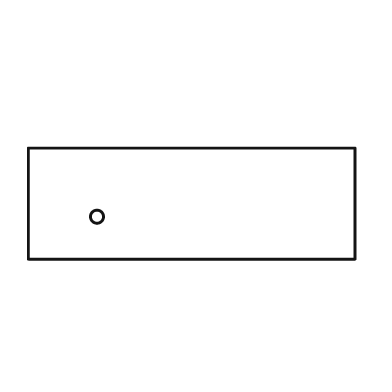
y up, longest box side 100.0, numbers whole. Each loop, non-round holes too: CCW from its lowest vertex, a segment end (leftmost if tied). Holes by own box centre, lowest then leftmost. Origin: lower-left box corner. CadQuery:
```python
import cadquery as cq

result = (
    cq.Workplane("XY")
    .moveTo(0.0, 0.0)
    .lineTo(100.0, 0.0)
    .lineTo(100.0, 34.0)
    .lineTo(0.0, 34.0)
    .close()
    .moveTo(21.0, 13.0)
    .circle(2.0)
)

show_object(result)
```